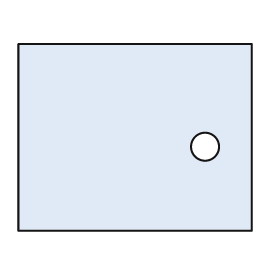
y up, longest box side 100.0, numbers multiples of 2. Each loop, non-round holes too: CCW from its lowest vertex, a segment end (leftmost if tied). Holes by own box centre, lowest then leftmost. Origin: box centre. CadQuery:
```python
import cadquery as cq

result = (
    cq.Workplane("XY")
    .moveTo(-50.0, -40.0)
    .lineTo(50.0, -40.0)
    .lineTo(50.0, 40.0)
    .lineTo(-50.0, 40.0)
    .close()
    .moveTo(30.0, -4.0)
    .circle(6.0)
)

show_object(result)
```